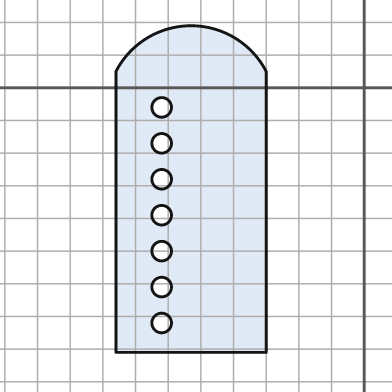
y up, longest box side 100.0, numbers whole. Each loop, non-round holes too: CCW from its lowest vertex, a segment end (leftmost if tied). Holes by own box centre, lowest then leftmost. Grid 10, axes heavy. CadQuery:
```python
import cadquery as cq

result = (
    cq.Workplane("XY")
    .moveTo(-76.0, -81.0)
    .lineTo(-30.0, -81.0)
    .lineTo(-30.0, 5.0)
    .threePointArc((-53.0, 19.0), (-76.0, 5.0))
    .close()
    .moveTo(-62.0, -72.0)
    .circle(3.0)
    .moveTo(-62.0, -61.0)
    .circle(3.0)
    .moveTo(-62.0, -50.0)
    .circle(3.0)
    .moveTo(-62.0, -39.0)
    .circle(3.0)
    .moveTo(-62.0, -28.0)
    .circle(3.0)
    .moveTo(-62.0, -17.0)
    .circle(3.0)
    .moveTo(-62.0, -6.0)
    .circle(3.0)
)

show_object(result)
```